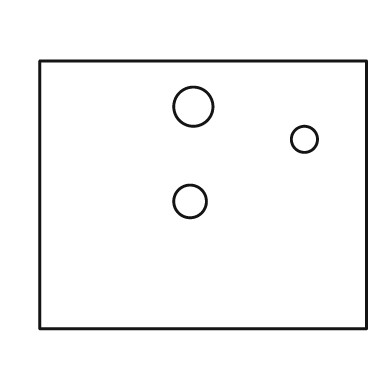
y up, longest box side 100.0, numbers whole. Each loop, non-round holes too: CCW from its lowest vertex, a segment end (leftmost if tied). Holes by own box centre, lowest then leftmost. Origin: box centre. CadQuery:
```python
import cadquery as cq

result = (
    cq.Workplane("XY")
    .moveTo(-50.0, -41.0)
    .lineTo(50.0, -41.0)
    .lineTo(50.0, 41.0)
    .lineTo(-50.0, 41.0)
    .close()
    .moveTo(-4.0, -2.0)
    .circle(5.0)
    .moveTo(31.0, 17.0)
    .circle(4.0)
    .moveTo(-3.0, 27.0)
    .circle(6.0)
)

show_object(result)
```